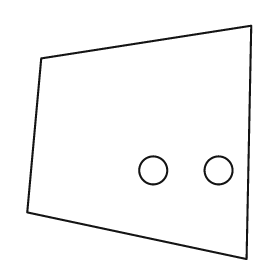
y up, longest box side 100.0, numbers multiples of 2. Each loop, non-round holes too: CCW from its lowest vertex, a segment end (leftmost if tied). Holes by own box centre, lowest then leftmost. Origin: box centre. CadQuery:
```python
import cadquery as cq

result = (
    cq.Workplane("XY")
    .moveTo(46.0, -50.0)
    .lineTo(48.0, 50.0)
    .lineTo(-42.0, 36.0)
    .lineTo(-48.0, -30.0)
    .close()
    .moveTo(6.0, -12.0)
    .circle(6.0)
    .moveTo(34.0, -12.0)
    .circle(6.0)
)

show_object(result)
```